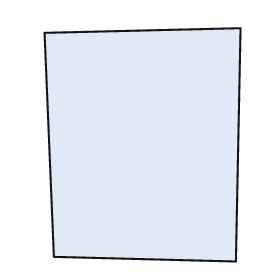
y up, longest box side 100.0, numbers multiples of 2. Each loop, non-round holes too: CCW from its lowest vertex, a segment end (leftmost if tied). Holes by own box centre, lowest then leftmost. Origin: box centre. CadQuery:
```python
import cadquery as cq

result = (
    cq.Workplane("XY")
    .moveTo(40.0, -50.0)
    .lineTo(42.0, 50.0)
    .lineTo(-42.0, 48.0)
    .lineTo(-38.0, -48.0)
    .close()
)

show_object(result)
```